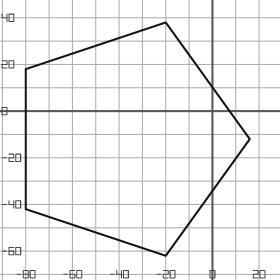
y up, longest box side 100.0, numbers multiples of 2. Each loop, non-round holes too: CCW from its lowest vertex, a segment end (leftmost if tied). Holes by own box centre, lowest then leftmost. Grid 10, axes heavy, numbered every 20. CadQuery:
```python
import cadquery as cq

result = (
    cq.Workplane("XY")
    .moveTo(-20.0, -62.0)
    .lineTo(16.0, -12.0)
    .lineTo(-20.0, 38.0)
    .lineTo(-80.0, 18.0)
    .lineTo(-80.0, -42.0)
    .close()
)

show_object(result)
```